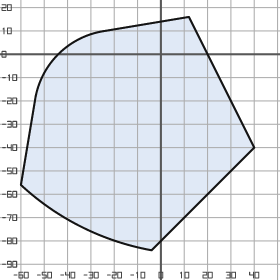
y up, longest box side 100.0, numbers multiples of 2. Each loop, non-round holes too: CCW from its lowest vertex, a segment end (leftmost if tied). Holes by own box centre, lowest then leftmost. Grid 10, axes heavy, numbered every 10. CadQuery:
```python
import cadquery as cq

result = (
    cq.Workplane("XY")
    .moveTo(-4.0, -84.0)
    .lineTo(40.0, -40.0)
    .lineTo(12.0, 16.0)
    .lineTo(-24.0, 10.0)
    .threePointArc((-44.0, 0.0), (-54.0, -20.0))
    .lineTo(-60.0, -56.0)
    .threePointArc((-34.0, -74.0), (-4.0, -84.0))
    .close()
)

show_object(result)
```